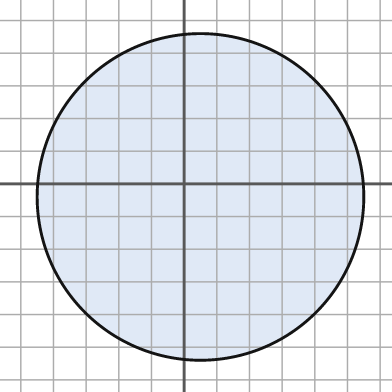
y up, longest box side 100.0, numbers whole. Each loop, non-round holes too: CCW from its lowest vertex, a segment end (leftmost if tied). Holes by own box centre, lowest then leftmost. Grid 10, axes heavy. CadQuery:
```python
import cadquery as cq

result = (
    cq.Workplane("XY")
    .moveTo(5.0, -4.0)
    .circle(50.0)
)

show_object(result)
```